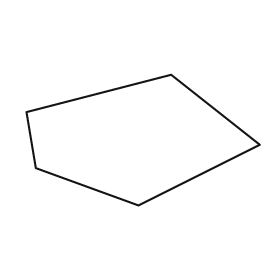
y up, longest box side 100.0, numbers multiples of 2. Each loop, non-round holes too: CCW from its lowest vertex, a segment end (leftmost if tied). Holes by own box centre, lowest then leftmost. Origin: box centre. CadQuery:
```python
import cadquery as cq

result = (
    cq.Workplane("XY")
    .moveTo(-2.0, -28.0)
    .lineTo(50.0, -2.0)
    .lineTo(12.0, 28.0)
    .lineTo(-50.0, 12.0)
    .lineTo(-46.0, -12.0)
    .close()
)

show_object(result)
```